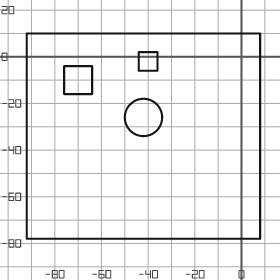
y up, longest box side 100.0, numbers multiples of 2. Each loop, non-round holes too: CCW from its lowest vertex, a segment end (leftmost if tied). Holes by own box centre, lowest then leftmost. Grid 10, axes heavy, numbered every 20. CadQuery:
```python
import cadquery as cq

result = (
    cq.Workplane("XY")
    .moveTo(-92.0, -78.0)
    .lineTo(8.0, -78.0)
    .lineTo(8.0, 10.0)
    .lineTo(-92.0, 10.0)
    .close()
    .moveTo(-42.0, -26.0)
    .circle(8.0)
    .moveTo(-76.0, -16.0)
    .lineTo(-64.0, -16.0)
    .lineTo(-64.0, -4.0)
    .lineTo(-76.0, -4.0)
    .close()
    .moveTo(-44.0, -6.0)
    .lineTo(-36.0, -6.0)
    .lineTo(-36.0, 2.0)
    .lineTo(-44.0, 2.0)
    .close()
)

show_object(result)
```